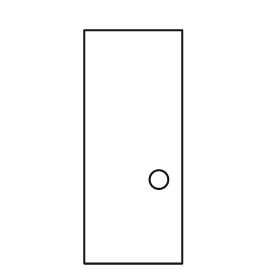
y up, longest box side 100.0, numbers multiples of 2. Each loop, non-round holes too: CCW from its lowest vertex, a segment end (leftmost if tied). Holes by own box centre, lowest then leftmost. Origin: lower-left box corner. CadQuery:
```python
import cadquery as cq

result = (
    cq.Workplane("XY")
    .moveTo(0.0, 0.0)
    .lineTo(42.0, 0.0)
    .lineTo(42.0, 100.0)
    .lineTo(0.0, 100.0)
    .close()
    .moveTo(32.0, 36.0)
    .circle(4.0)
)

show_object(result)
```